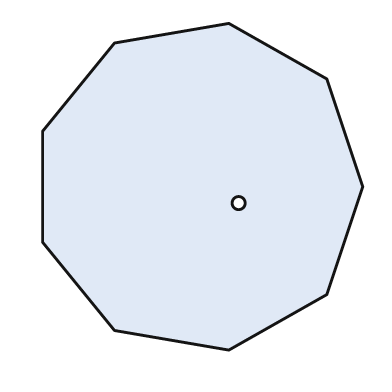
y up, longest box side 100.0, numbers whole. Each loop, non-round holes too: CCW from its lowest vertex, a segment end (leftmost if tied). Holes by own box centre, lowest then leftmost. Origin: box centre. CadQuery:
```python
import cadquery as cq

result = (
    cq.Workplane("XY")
    .moveTo(8.0, -50.0)
    .lineTo(38.0, -33.0)
    .lineTo(49.0, 0.0)
    .lineTo(38.0, 33.0)
    .lineTo(8.0, 50.0)
    .lineTo(-27.0, 44.0)
    .lineTo(-49.0, 17.0)
    .lineTo(-49.0, -17.0)
    .lineTo(-27.0, -44.0)
    .close()
    .moveTo(11.0, -5.0)
    .circle(2.0)
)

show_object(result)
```